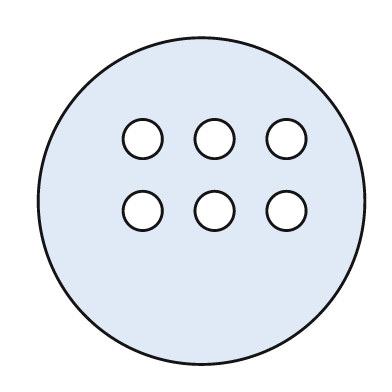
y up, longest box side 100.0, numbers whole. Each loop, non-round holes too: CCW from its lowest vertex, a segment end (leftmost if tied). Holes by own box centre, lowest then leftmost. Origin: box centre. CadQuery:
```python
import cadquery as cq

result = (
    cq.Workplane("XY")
    .moveTo(0.0, 0.0)
    .circle(50.0)
    .moveTo(-18.0, -3.0)
    .circle(6.0)
    .moveTo(4.0, -3.0)
    .circle(6.0)
    .moveTo(26.0, -3.0)
    .circle(6.0)
    .moveTo(-18.0, 19.0)
    .circle(6.0)
    .moveTo(4.0, 19.0)
    .circle(6.0)
    .moveTo(26.0, 19.0)
    .circle(6.0)
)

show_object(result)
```